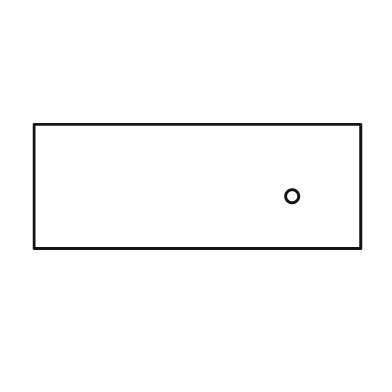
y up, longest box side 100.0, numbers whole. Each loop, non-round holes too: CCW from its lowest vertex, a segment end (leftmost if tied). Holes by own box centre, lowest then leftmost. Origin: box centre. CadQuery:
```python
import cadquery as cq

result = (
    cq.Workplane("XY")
    .moveTo(-50.0, -19.0)
    .lineTo(50.0, -19.0)
    .lineTo(50.0, 19.0)
    .lineTo(-50.0, 19.0)
    .close()
    .moveTo(29.0, -3.0)
    .circle(2.0)
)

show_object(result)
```